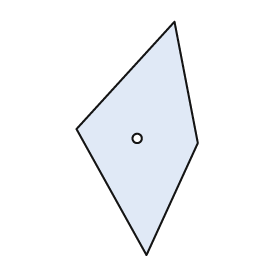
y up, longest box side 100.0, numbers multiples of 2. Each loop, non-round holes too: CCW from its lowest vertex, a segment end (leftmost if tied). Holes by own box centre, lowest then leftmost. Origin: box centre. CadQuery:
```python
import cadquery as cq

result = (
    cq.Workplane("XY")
    .moveTo(4.0, -50.0)
    .lineTo(26.0, -2.0)
    .lineTo(16.0, 50.0)
    .lineTo(-26.0, 4.0)
    .close()
    .moveTo(0.0, 0.0)
    .circle(2.0)
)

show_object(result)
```